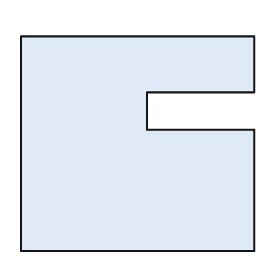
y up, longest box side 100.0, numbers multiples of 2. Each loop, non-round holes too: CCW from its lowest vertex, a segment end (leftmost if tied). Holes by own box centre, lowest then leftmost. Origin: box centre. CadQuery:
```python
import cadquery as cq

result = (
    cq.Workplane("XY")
    .moveTo(-50.0, -46.0)
    .lineTo(50.0, -46.0)
    .lineTo(50.0, 6.0)
    .lineTo(4.0, 6.0)
    .lineTo(4.0, 22.0)
    .lineTo(50.0, 22.0)
    .lineTo(50.0, 46.0)
    .lineTo(-50.0, 46.0)
    .close()
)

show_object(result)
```